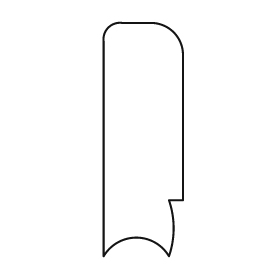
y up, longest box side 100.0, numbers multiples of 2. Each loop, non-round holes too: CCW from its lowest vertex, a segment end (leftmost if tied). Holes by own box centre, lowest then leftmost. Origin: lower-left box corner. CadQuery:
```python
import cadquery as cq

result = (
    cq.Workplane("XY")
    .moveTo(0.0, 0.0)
    .threePointArc((14.0, 8.0), (28.0, 0.0))
    .threePointArc((30.0, 12.0), (28.0, 24.0))
    .lineTo(34.0, 24.0)
    .lineTo(34.0, 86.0)
    .threePointArc((30.0, 96.0), (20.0, 100.0))
    .lineTo(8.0, 100.0)
    .threePointArc((2.0, 98.0), (0.0, 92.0))
    .close()
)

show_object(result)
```